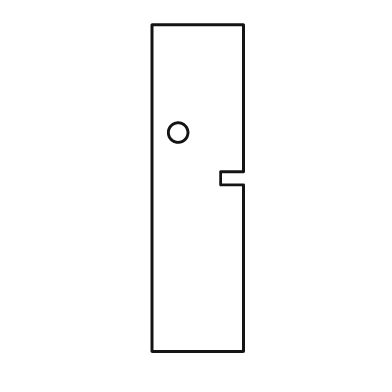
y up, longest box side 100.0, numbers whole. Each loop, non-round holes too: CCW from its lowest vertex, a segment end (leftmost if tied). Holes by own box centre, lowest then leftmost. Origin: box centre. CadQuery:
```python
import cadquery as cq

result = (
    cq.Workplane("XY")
    .moveTo(-14.0, -50.0)
    .lineTo(14.0, -50.0)
    .lineTo(14.0, 1.0)
    .lineTo(7.0, 1.0)
    .lineTo(7.0, 5.0)
    .lineTo(14.0, 5.0)
    .lineTo(14.0, 50.0)
    .lineTo(-14.0, 50.0)
    .close()
    .moveTo(-6.0, 17.0)
    .circle(3.0)
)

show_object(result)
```